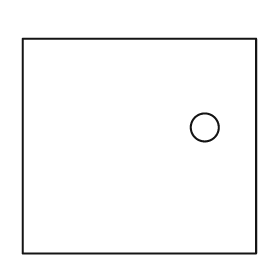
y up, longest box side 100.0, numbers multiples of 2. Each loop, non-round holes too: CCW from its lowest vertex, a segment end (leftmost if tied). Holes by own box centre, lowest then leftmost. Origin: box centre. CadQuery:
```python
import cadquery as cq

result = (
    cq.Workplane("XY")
    .moveTo(-50.0, -46.0)
    .lineTo(50.0, -46.0)
    .lineTo(50.0, 46.0)
    .lineTo(-50.0, 46.0)
    .close()
    .moveTo(28.0, 8.0)
    .circle(6.0)
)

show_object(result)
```